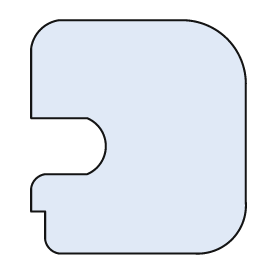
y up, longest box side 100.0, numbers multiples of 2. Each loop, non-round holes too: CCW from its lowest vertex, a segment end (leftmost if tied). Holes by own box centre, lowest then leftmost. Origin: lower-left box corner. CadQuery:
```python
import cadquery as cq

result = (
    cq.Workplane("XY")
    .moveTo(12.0, 0.0)
    .lineTo(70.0, 0.0)
    .threePointArc((86.0, 6.0), (92.0, 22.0))
    .lineTo(92.0, 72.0)
    .threePointArc((84.0, 92.0), (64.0, 100.0))
    .lineTo(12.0, 100.0)
    .threePointArc((4.0, 96.0), (0.0, 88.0))
    .lineTo(0.0, 58.0)
    .lineTo(24.0, 58.0)
    .threePointArc((32.0, 46.0), (24.0, 34.0))
    .lineTo(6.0, 34.0)
    .threePointArc((2.0, 32.0), (0.0, 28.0))
    .lineTo(0.0, 18.0)
    .lineTo(6.0, 18.0)
    .lineTo(6.0, 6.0)
    .threePointArc((8.0, 2.0), (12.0, 0.0))
    .close()
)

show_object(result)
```